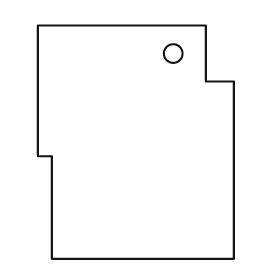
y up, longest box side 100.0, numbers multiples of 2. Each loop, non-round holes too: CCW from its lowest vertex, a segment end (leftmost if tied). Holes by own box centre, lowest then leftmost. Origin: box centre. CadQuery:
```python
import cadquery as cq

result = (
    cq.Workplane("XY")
    .moveTo(-36.0, -50.0)
    .lineTo(42.0, -50.0)
    .lineTo(42.0, 26.0)
    .lineTo(30.0, 26.0)
    .lineTo(30.0, 50.0)
    .lineTo(-42.0, 50.0)
    .lineTo(-42.0, -6.0)
    .lineTo(-36.0, -6.0)
    .close()
    .moveTo(16.0, 38.0)
    .circle(4.0)
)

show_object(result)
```